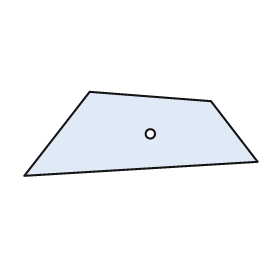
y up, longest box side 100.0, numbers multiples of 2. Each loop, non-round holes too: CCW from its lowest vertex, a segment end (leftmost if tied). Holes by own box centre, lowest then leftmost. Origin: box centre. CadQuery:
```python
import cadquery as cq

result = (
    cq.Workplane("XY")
    .moveTo(-50.0, -18.0)
    .lineTo(50.0, -12.0)
    .lineTo(30.0, 14.0)
    .lineTo(-22.0, 18.0)
    .close()
    .moveTo(4.0, 0.0)
    .circle(2.0)
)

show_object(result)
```